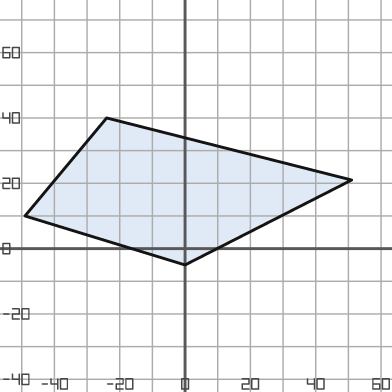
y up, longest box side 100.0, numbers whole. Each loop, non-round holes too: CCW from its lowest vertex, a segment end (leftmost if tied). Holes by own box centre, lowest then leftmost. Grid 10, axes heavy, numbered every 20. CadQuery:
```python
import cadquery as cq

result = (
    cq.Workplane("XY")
    .moveTo(0.0, -5.0)
    .lineTo(51.0, 21.0)
    .lineTo(-24.0, 40.0)
    .lineTo(-49.0, 10.0)
    .close()
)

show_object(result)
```